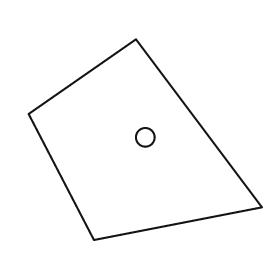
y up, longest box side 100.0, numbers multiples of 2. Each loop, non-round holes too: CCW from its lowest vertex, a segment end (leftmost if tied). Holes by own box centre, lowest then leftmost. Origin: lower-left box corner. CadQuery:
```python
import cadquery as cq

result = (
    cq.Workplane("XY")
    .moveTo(28.0, 0.0)
    .lineTo(100.0, 14.0)
    .lineTo(46.0, 86.0)
    .lineTo(0.0, 54.0)
    .close()
    .moveTo(50.0, 44.0)
    .circle(4.0)
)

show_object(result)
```